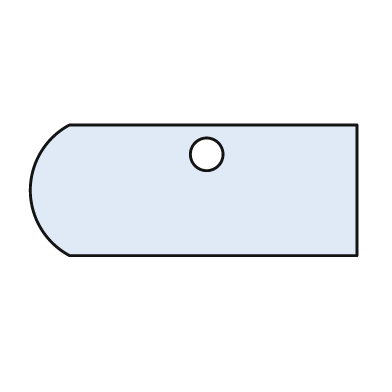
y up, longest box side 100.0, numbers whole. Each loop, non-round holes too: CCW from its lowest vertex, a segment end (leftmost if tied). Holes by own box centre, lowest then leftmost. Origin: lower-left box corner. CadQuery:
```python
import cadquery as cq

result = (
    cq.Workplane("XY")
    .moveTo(12.0, 0.0)
    .lineTo(100.0, 0.0)
    .lineTo(100.0, 40.0)
    .lineTo(12.0, 40.0)
    .threePointArc((0.0, 20.0), (12.0, 0.0))
    .close()
    .moveTo(54.0, 31.0)
    .circle(5.0)
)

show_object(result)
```